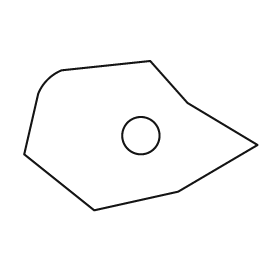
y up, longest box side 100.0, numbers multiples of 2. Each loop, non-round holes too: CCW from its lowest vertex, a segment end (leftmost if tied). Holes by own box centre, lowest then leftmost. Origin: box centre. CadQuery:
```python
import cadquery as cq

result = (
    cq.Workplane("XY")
    .moveTo(-20.0, -32.0)
    .lineTo(16.0, -24.0)
    .lineTo(50.0, -4.0)
    .lineTo(20.0, 14.0)
    .lineTo(4.0, 32.0)
    .lineTo(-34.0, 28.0)
    .threePointArc((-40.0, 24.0), (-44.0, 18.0))
    .lineTo(-50.0, -8.0)
    .close()
    .moveTo(0.0, 0.0)
    .circle(8.0)
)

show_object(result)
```